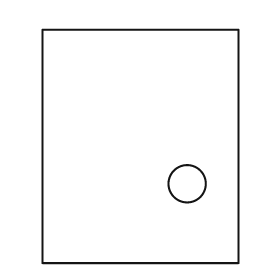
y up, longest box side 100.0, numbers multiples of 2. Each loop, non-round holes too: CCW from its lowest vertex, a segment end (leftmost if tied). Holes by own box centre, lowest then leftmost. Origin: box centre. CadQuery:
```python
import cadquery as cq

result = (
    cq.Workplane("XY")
    .moveTo(-42.0, -50.0)
    .lineTo(42.0, -50.0)
    .lineTo(42.0, 50.0)
    .lineTo(-42.0, 50.0)
    .close()
    .moveTo(20.0, -16.0)
    .circle(8.0)
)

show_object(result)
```